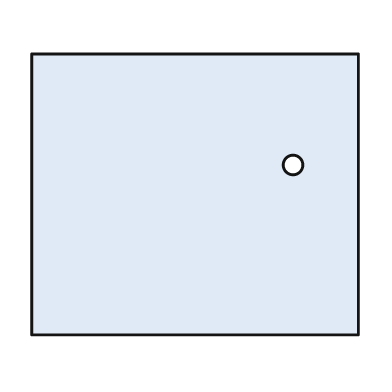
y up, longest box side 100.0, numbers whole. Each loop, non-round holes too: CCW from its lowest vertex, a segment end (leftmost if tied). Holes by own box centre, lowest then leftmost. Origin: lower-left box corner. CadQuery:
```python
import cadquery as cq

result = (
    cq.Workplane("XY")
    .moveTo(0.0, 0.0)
    .lineTo(100.0, 0.0)
    .lineTo(100.0, 86.0)
    .lineTo(0.0, 86.0)
    .close()
    .moveTo(80.0, 52.0)
    .circle(3.0)
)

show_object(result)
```